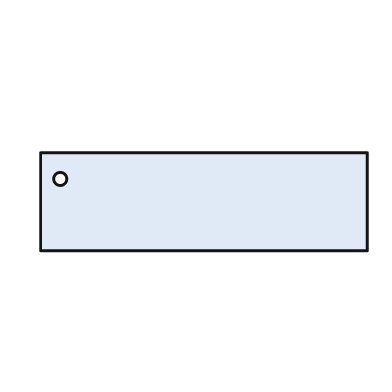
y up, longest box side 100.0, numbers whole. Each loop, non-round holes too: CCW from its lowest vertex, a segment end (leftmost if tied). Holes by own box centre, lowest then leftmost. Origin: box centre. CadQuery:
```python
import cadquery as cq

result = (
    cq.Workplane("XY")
    .moveTo(-50.0, -15.0)
    .lineTo(50.0, -15.0)
    .lineTo(50.0, 15.0)
    .lineTo(-50.0, 15.0)
    .close()
    .moveTo(-44.0, 7.0)
    .circle(2.0)
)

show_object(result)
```